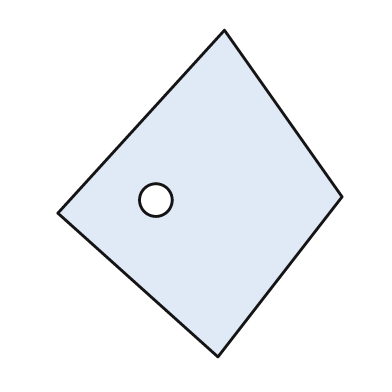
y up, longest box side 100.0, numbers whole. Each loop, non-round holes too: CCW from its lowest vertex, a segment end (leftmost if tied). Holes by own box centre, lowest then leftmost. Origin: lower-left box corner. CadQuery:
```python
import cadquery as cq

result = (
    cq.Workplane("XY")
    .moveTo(49.0, 0.0)
    .lineTo(87.0, 49.0)
    .lineTo(51.0, 100.0)
    .lineTo(0.0, 44.0)
    .close()
    .moveTo(30.0, 48.0)
    .circle(5.0)
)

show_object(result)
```